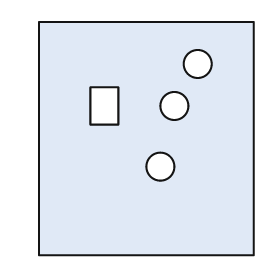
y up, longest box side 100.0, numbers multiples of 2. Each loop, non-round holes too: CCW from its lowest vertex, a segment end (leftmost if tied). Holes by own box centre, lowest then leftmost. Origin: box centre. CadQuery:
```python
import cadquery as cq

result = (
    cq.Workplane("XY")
    .moveTo(-46.0, -50.0)
    .lineTo(46.0, -50.0)
    .lineTo(46.0, 50.0)
    .lineTo(-46.0, 50.0)
    .close()
    .moveTo(6.0, -12.0)
    .circle(6.0)
    .moveTo(-24.0, 6.0)
    .lineTo(-12.0, 6.0)
    .lineTo(-12.0, 22.0)
    .lineTo(-24.0, 22.0)
    .close()
    .moveTo(12.0, 14.0)
    .circle(6.0)
    .moveTo(22.0, 32.0)
    .circle(6.0)
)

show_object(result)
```